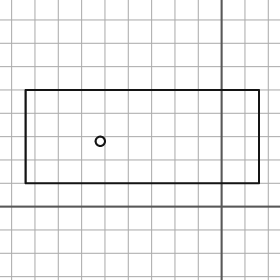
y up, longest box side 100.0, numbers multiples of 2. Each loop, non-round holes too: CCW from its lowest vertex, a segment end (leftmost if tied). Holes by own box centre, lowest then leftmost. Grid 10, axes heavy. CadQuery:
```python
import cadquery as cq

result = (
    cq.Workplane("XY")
    .moveTo(-84.0, 10.0)
    .lineTo(16.0, 10.0)
    .lineTo(16.0, 50.0)
    .lineTo(-84.0, 50.0)
    .close()
    .moveTo(-52.0, 28.0)
    .circle(2.0)
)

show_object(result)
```